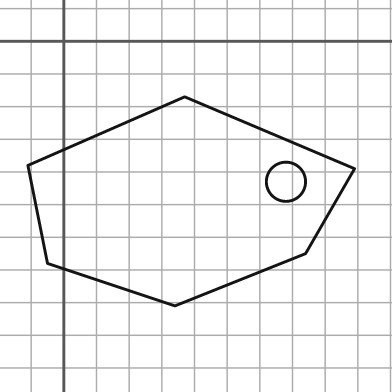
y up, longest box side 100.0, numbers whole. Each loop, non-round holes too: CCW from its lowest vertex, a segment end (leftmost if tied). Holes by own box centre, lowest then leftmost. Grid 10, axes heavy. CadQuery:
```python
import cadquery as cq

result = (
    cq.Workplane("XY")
    .moveTo(34.0, -81.0)
    .lineTo(74.0, -65.0)
    .lineTo(89.0, -39.0)
    .lineTo(37.0, -17.0)
    .lineTo(-11.0, -38.0)
    .lineTo(-5.0, -68.0)
    .close()
    .moveTo(68.0, -43.0)
    .circle(6.0)
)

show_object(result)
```